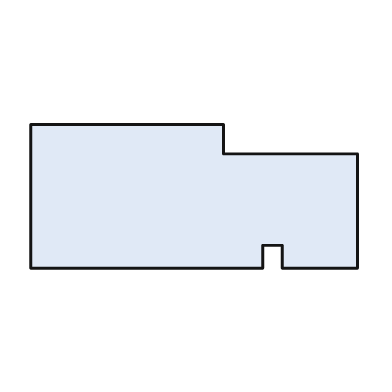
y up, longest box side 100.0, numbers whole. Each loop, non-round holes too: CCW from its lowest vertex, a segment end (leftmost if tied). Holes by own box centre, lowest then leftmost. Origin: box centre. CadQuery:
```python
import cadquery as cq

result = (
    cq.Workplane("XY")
    .moveTo(-50.0, -22.0)
    .lineTo(21.0, -22.0)
    .lineTo(21.0, -15.0)
    .lineTo(27.0, -15.0)
    .lineTo(27.0, -22.0)
    .lineTo(50.0, -22.0)
    .lineTo(50.0, 13.0)
    .lineTo(9.0, 13.0)
    .lineTo(9.0, 22.0)
    .lineTo(-50.0, 22.0)
    .close()
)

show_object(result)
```